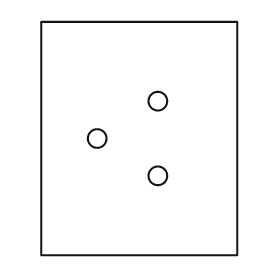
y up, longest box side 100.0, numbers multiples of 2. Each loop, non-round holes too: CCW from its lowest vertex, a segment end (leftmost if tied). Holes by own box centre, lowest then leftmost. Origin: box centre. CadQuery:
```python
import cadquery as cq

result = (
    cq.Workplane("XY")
    .moveTo(-42.0, -50.0)
    .lineTo(42.0, -50.0)
    .lineTo(42.0, 50.0)
    .lineTo(-42.0, 50.0)
    .close()
    .moveTo(8.0, -16.0)
    .circle(4.0)
    .moveTo(-18.0, 0.0)
    .circle(4.0)
    .moveTo(8.0, 16.0)
    .circle(4.0)
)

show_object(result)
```